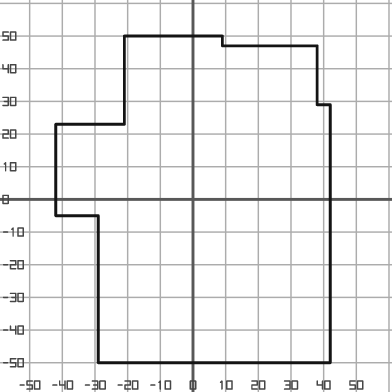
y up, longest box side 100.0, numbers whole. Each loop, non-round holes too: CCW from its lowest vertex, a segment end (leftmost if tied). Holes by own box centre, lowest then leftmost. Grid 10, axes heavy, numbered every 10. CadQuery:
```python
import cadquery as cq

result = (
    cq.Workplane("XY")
    .moveTo(-29.0, -50.0)
    .lineTo(42.0, -50.0)
    .lineTo(42.0, 29.0)
    .lineTo(38.0, 29.0)
    .lineTo(38.0, 47.0)
    .lineTo(9.0, 47.0)
    .lineTo(9.0, 50.0)
    .lineTo(-21.0, 50.0)
    .lineTo(-21.0, 23.0)
    .lineTo(-42.0, 23.0)
    .lineTo(-42.0, -5.0)
    .lineTo(-29.0, -5.0)
    .close()
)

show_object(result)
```